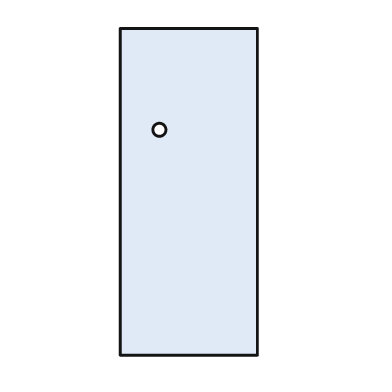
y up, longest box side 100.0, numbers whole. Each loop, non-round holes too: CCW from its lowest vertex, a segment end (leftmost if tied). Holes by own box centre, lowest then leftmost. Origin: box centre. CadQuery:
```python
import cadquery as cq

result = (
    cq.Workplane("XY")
    .moveTo(-21.0, -50.0)
    .lineTo(21.0, -50.0)
    .lineTo(21.0, 50.0)
    .lineTo(-21.0, 50.0)
    .close()
    .moveTo(-9.0, 19.0)
    .circle(2.0)
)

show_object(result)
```